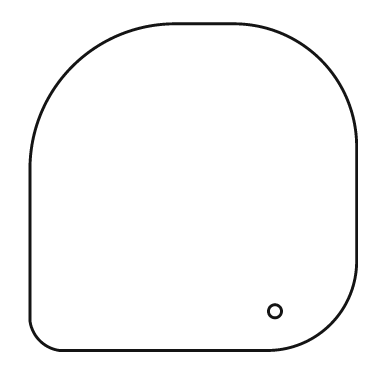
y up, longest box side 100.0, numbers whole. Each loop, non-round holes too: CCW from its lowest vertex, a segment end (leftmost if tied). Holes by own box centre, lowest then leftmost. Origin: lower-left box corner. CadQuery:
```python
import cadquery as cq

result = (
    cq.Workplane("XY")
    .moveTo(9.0, 0.0)
    .lineTo(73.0, 0.0)
    .threePointArc((92.0, 8.0), (100.0, 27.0))
    .lineTo(100.0, 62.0)
    .threePointArc((89.0, 89.0), (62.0, 100.0))
    .lineTo(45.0, 100.0)
    .threePointArc((13.0, 87.0), (0.0, 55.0))
    .lineTo(0.0, 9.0)
    .threePointArc((3.0, 3.0), (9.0, 0.0))
    .close()
    .moveTo(75.0, 12.0)
    .circle(2.0)
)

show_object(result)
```